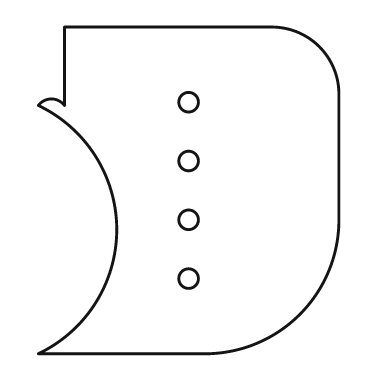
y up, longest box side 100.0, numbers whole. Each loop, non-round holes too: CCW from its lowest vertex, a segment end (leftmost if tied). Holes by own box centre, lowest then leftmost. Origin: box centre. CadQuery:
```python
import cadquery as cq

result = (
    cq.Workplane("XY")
    .moveTo(-46.0, -50.0)
    .lineTo(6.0, -50.0)
    .threePointArc((34.0, -38.0), (46.0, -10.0))
    .lineTo(46.0, 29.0)
    .threePointArc((40.0, 44.0), (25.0, 50.0))
    .lineTo(-38.0, 50.0)
    .lineTo(-38.0, 26.0)
    .threePointArc((-42.0, 28.0), (-46.0, 26.0))
    .threePointArc((-22.0, -12.0), (-46.0, -50.0))
    .close()
    .moveTo(0.0, -27.0)
    .circle(3.0)
    .moveTo(0.0, -9.0)
    .circle(3.0)
    .moveTo(0.0, 9.0)
    .circle(3.0)
    .moveTo(0.0, 27.0)
    .circle(3.0)
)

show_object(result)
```